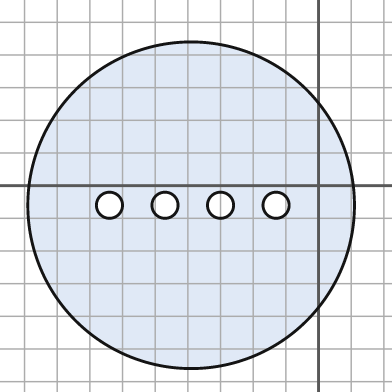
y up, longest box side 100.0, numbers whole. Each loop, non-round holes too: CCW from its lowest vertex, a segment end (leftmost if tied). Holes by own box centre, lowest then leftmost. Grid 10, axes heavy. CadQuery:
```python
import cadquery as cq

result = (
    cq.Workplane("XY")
    .moveTo(-39.0, -6.0)
    .circle(50.0)
    .moveTo(-64.0, -6.0)
    .circle(4.0)
    .moveTo(-47.0, -6.0)
    .circle(4.0)
    .moveTo(-30.0, -6.0)
    .circle(4.0)
    .moveTo(-13.0, -6.0)
    .circle(4.0)
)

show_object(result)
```